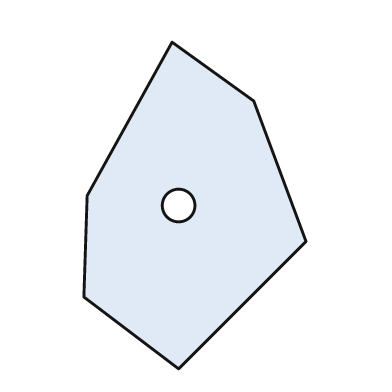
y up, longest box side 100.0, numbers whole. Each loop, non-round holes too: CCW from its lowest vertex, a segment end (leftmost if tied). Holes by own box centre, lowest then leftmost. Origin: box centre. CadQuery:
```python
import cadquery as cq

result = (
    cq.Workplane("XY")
    .moveTo(-5.0, -50.0)
    .lineTo(34.0, -11.0)
    .lineTo(18.0, 32.0)
    .lineTo(-7.0, 50.0)
    .lineTo(-33.0, 3.0)
    .lineTo(-34.0, -28.0)
    .close()
    .moveTo(-5.0, 0.0)
    .circle(5.0)
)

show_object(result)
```